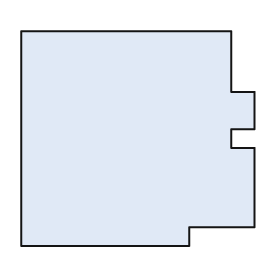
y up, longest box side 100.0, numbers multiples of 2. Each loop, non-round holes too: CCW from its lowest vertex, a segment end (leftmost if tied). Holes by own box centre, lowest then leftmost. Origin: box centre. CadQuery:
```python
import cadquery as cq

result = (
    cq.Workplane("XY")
    .moveTo(-50.0, -46.0)
    .lineTo(22.0, -46.0)
    .lineTo(22.0, -38.0)
    .lineTo(50.0, -38.0)
    .lineTo(50.0, -4.0)
    .lineTo(40.0, -4.0)
    .lineTo(40.0, 4.0)
    .lineTo(50.0, 4.0)
    .lineTo(50.0, 20.0)
    .lineTo(40.0, 20.0)
    .lineTo(40.0, 46.0)
    .lineTo(-50.0, 46.0)
    .close()
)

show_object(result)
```